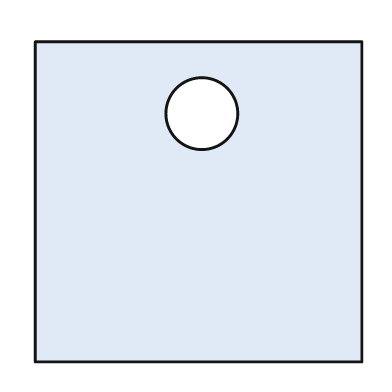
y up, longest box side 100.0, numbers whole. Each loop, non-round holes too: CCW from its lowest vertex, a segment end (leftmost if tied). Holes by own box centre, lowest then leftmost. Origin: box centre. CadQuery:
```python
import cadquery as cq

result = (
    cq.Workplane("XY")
    .moveTo(-50.0, -49.0)
    .lineTo(50.0, -49.0)
    .lineTo(50.0, 49.0)
    .lineTo(-50.0, 49.0)
    .close()
    .moveTo(1.0, 27.0)
    .circle(11.0)
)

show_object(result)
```